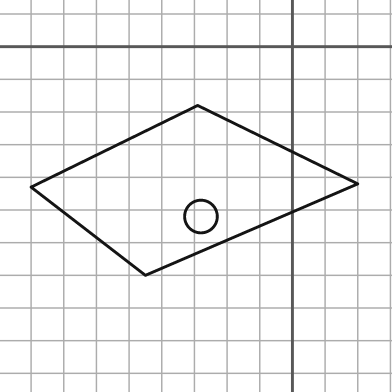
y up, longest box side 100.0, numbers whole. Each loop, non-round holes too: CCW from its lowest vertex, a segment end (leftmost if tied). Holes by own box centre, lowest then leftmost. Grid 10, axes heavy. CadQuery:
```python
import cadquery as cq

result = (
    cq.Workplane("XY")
    .moveTo(-45.0, -70.0)
    .lineTo(20.0, -42.0)
    .lineTo(-29.0, -18.0)
    .lineTo(-80.0, -43.0)
    .close()
    .moveTo(-28.0, -52.0)
    .circle(5.0)
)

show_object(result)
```